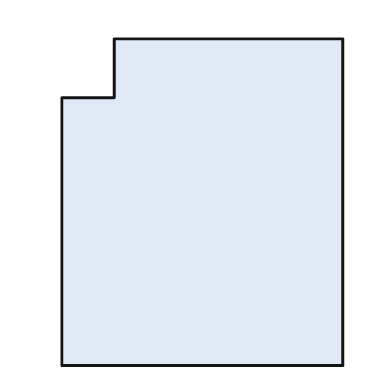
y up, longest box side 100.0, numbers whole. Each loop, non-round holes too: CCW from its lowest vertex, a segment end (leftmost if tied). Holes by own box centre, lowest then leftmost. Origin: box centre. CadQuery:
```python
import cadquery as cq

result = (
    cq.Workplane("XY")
    .moveTo(-43.0, -50.0)
    .lineTo(43.0, -50.0)
    .lineTo(43.0, 50.0)
    .lineTo(-27.0, 50.0)
    .lineTo(-27.0, 32.0)
    .lineTo(-43.0, 32.0)
    .close()
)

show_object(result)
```